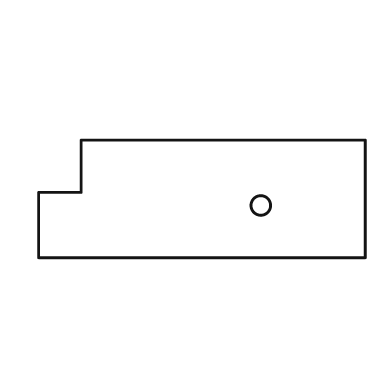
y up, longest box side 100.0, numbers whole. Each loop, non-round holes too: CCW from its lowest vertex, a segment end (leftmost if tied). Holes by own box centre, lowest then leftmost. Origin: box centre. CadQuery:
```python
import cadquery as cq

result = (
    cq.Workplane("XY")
    .moveTo(-50.0, -18.0)
    .lineTo(50.0, -18.0)
    .lineTo(50.0, 18.0)
    .lineTo(-37.0, 18.0)
    .lineTo(-37.0, 2.0)
    .lineTo(-50.0, 2.0)
    .close()
    .moveTo(18.0, -2.0)
    .circle(3.0)
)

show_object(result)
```